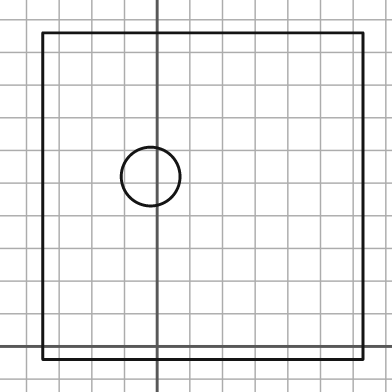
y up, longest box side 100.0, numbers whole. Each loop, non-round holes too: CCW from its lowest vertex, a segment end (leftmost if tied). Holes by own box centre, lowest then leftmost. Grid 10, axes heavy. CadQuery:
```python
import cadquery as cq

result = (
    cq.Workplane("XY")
    .moveTo(-35.0, -4.0)
    .lineTo(63.0, -4.0)
    .lineTo(63.0, 96.0)
    .lineTo(-35.0, 96.0)
    .close()
    .moveTo(-2.0, 52.0)
    .circle(9.0)
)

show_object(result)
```